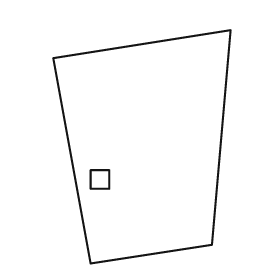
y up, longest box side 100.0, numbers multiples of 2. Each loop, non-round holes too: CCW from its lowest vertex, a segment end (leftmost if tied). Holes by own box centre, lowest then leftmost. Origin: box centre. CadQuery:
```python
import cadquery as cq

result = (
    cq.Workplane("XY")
    .moveTo(-22.0, -50.0)
    .lineTo(30.0, -42.0)
    .lineTo(38.0, 50.0)
    .lineTo(-38.0, 38.0)
    .close()
    .moveTo(-22.0, -18.0)
    .lineTo(-14.0, -18.0)
    .lineTo(-14.0, -10.0)
    .lineTo(-22.0, -10.0)
    .close()
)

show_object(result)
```